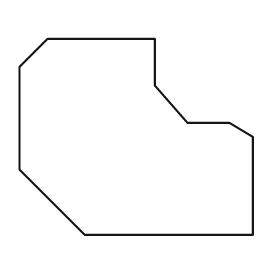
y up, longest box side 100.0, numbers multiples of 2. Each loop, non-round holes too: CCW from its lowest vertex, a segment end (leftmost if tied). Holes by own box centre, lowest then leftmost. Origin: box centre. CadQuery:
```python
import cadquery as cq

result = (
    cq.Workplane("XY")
    .moveTo(-22.0, -42.0)
    .lineTo(50.0, -42.0)
    .lineTo(50.0, 0.0)
    .lineTo(40.0, 6.0)
    .lineTo(22.0, 6.0)
    .lineTo(8.0, 22.0)
    .lineTo(8.0, 42.0)
    .lineTo(-38.0, 42.0)
    .lineTo(-50.0, 30.0)
    .lineTo(-50.0, -14.0)
    .close()
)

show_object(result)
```